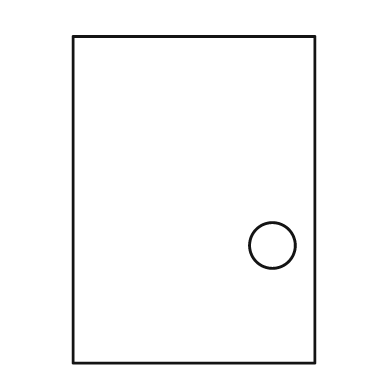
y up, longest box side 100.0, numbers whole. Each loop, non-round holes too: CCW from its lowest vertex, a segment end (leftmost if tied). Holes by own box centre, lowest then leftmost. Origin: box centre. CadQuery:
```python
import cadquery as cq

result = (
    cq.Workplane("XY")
    .moveTo(-37.0, -50.0)
    .lineTo(37.0, -50.0)
    .lineTo(37.0, 50.0)
    .lineTo(-37.0, 50.0)
    .close()
    .moveTo(24.0, -14.0)
    .circle(7.0)
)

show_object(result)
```